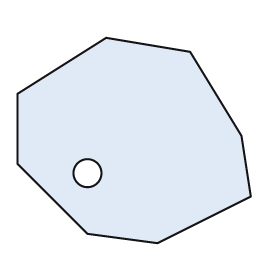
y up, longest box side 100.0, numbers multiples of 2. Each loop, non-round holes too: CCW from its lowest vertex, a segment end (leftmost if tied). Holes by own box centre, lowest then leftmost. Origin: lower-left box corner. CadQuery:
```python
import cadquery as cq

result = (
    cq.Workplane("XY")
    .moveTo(60.0, 0.0)
    .lineTo(100.0, 20.0)
    .lineTo(96.0, 46.0)
    .lineTo(74.0, 82.0)
    .lineTo(38.0, 88.0)
    .lineTo(0.0, 64.0)
    .lineTo(0.0, 34.0)
    .lineTo(30.0, 4.0)
    .close()
    .moveTo(30.0, 30.0)
    .circle(6.0)
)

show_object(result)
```